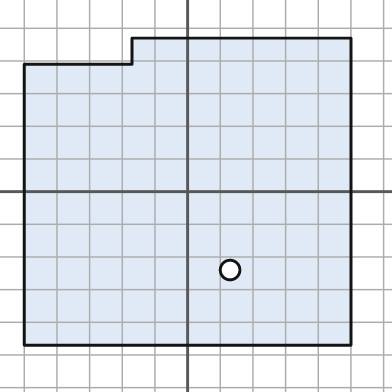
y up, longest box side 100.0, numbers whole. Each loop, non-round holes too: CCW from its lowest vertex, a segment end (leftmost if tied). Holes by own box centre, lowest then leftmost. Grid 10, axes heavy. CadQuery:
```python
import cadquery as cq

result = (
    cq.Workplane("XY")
    .moveTo(-50.0, -47.0)
    .lineTo(50.0, -47.0)
    .lineTo(50.0, 47.0)
    .lineTo(-17.0, 47.0)
    .lineTo(-17.0, 39.0)
    .lineTo(-50.0, 39.0)
    .close()
    .moveTo(13.0, -24.0)
    .circle(3.0)
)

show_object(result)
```